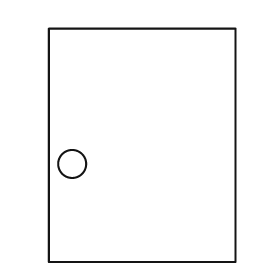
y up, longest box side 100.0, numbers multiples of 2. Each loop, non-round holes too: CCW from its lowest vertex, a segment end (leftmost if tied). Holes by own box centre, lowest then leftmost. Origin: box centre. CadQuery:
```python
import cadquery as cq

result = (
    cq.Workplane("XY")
    .moveTo(-40.0, -50.0)
    .lineTo(40.0, -50.0)
    .lineTo(40.0, 50.0)
    .lineTo(-40.0, 50.0)
    .close()
    .moveTo(-30.0, -8.0)
    .circle(6.0)
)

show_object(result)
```